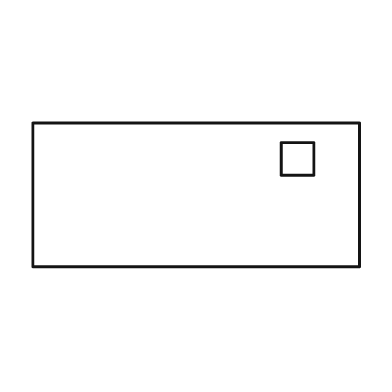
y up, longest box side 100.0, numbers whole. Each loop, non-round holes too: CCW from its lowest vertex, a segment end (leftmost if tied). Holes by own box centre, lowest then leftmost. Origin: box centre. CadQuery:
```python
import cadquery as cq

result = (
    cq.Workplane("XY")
    .moveTo(-50.0, -22.0)
    .lineTo(50.0, -22.0)
    .lineTo(50.0, 22.0)
    .lineTo(-50.0, 22.0)
    .close()
    .moveTo(26.0, 6.0)
    .lineTo(36.0, 6.0)
    .lineTo(36.0, 16.0)
    .lineTo(26.0, 16.0)
    .close()
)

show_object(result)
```